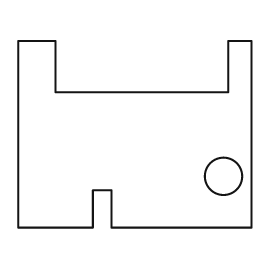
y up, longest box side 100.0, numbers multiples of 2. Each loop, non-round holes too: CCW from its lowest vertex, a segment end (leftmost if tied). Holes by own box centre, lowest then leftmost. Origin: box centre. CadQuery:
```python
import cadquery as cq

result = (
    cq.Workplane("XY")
    .moveTo(-50.0, -40.0)
    .lineTo(-18.0, -40.0)
    .lineTo(-18.0, -24.0)
    .lineTo(-10.0, -24.0)
    .lineTo(-10.0, -40.0)
    .lineTo(50.0, -40.0)
    .lineTo(50.0, 40.0)
    .lineTo(40.0, 40.0)
    .lineTo(40.0, 18.0)
    .lineTo(-34.0, 18.0)
    .lineTo(-34.0, 40.0)
    .lineTo(-50.0, 40.0)
    .close()
    .moveTo(38.0, -18.0)
    .circle(8.0)
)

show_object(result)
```